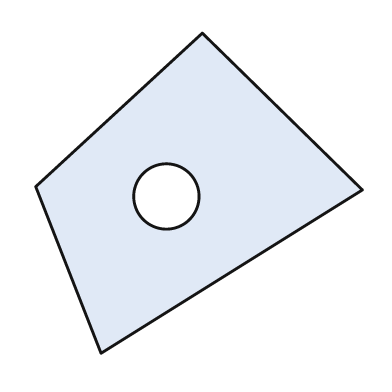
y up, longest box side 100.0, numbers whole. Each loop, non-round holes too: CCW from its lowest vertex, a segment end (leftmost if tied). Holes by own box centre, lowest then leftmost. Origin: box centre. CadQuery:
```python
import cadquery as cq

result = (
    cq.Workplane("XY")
    .moveTo(-30.0, -49.0)
    .lineTo(50.0, 1.0)
    .lineTo(1.0, 49.0)
    .lineTo(-50.0, 2.0)
    .close()
    .moveTo(-10.0, -1.0)
    .circle(10.0)
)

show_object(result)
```